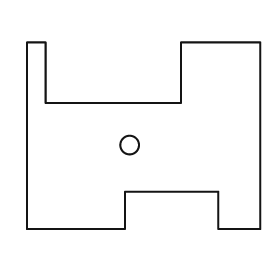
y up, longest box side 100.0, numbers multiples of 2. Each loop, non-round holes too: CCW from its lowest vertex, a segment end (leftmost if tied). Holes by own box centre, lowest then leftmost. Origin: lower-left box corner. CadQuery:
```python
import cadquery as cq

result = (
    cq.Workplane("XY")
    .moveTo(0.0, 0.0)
    .lineTo(42.0, 0.0)
    .lineTo(42.0, 16.0)
    .lineTo(82.0, 16.0)
    .lineTo(82.0, 0.0)
    .lineTo(100.0, 0.0)
    .lineTo(100.0, 80.0)
    .lineTo(66.0, 80.0)
    .lineTo(66.0, 54.0)
    .lineTo(8.0, 54.0)
    .lineTo(8.0, 80.0)
    .lineTo(0.0, 80.0)
    .close()
    .moveTo(44.0, 36.0)
    .circle(4.0)
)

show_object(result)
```